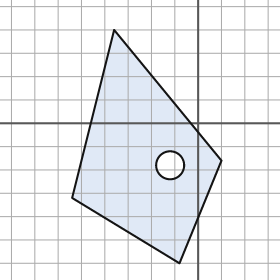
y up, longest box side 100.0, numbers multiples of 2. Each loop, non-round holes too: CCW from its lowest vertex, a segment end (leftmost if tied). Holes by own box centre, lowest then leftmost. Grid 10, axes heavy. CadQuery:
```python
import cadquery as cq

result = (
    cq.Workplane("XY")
    .moveTo(-8.0, -60.0)
    .lineTo(10.0, -16.0)
    .lineTo(-36.0, 40.0)
    .lineTo(-54.0, -32.0)
    .close()
    .moveTo(-12.0, -18.0)
    .circle(6.0)
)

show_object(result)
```